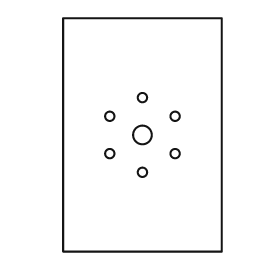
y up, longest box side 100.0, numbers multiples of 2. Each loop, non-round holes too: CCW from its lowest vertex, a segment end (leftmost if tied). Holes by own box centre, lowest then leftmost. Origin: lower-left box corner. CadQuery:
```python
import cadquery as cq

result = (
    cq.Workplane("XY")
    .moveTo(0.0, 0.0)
    .lineTo(68.0, 0.0)
    .lineTo(68.0, 100.0)
    .lineTo(0.0, 100.0)
    .close()
    .moveTo(34.0, 34.0)
    .circle(2.0)
    .moveTo(20.0, 42.0)
    .circle(2.0)
    .moveTo(48.0, 42.0)
    .circle(2.0)
    .moveTo(34.0, 50.0)
    .circle(4.0)
    .moveTo(20.0, 58.0)
    .circle(2.0)
    .moveTo(48.0, 58.0)
    .circle(2.0)
    .moveTo(34.0, 66.0)
    .circle(2.0)
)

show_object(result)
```